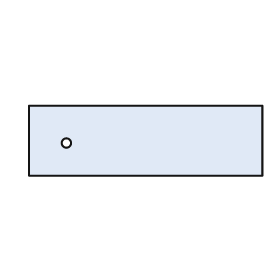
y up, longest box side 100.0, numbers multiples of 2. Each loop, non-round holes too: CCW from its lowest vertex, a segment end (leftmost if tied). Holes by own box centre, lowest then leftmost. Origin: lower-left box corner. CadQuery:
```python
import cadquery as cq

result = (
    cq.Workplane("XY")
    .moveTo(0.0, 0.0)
    .lineTo(100.0, 0.0)
    .lineTo(100.0, 30.0)
    .lineTo(0.0, 30.0)
    .close()
    .moveTo(16.0, 14.0)
    .circle(2.0)
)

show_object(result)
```